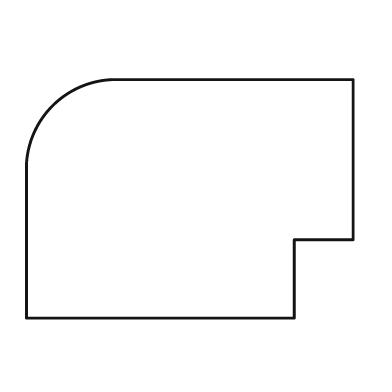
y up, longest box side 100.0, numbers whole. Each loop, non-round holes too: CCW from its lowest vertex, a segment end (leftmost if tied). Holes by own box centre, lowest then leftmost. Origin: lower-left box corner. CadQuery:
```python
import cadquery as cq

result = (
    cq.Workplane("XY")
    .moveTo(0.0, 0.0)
    .lineTo(82.0, 0.0)
    .lineTo(82.0, 24.0)
    .lineTo(100.0, 24.0)
    .lineTo(100.0, 73.0)
    .lineTo(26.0, 73.0)
    .threePointArc((8.0, 65.0), (0.0, 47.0))
    .close()
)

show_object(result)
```